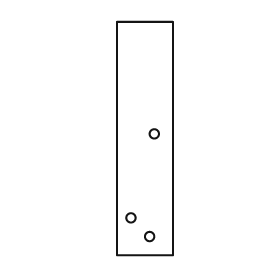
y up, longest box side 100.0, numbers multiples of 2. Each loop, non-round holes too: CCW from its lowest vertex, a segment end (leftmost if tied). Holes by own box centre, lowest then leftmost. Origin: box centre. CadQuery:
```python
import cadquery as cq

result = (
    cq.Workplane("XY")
    .moveTo(-12.0, -50.0)
    .lineTo(12.0, -50.0)
    .lineTo(12.0, 50.0)
    .lineTo(-12.0, 50.0)
    .close()
    .moveTo(2.0, -42.0)
    .circle(2.0)
    .moveTo(-6.0, -34.0)
    .circle(2.0)
    .moveTo(4.0, 2.0)
    .circle(2.0)
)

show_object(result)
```